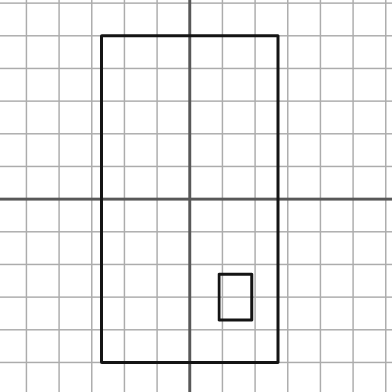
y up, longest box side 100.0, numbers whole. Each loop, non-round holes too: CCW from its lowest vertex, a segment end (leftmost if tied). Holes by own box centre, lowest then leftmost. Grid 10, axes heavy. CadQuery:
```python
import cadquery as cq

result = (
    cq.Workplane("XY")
    .moveTo(-27.0, -50.0)
    .lineTo(27.0, -50.0)
    .lineTo(27.0, 50.0)
    .lineTo(-27.0, 50.0)
    .close()
    .moveTo(9.0, -37.0)
    .lineTo(19.0, -37.0)
    .lineTo(19.0, -23.0)
    .lineTo(9.0, -23.0)
    .close()
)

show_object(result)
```